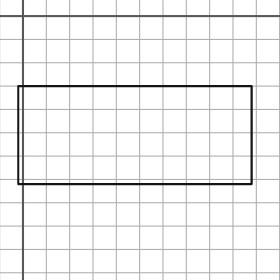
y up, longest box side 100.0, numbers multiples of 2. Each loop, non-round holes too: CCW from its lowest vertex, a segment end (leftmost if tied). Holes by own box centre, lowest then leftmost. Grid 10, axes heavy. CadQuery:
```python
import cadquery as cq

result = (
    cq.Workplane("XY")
    .moveTo(-2.0, -72.0)
    .lineTo(98.0, -72.0)
    .lineTo(98.0, -30.0)
    .lineTo(-2.0, -30.0)
    .close()
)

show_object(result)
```